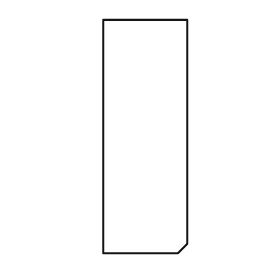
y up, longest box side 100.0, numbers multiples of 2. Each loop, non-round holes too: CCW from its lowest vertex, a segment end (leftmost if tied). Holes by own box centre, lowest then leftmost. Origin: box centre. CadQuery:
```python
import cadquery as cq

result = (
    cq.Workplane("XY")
    .moveTo(-18.0, -50.0)
    .lineTo(14.0, -50.0)
    .lineTo(18.0, -46.0)
    .lineTo(18.0, 50.0)
    .lineTo(-18.0, 50.0)
    .close()
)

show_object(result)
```